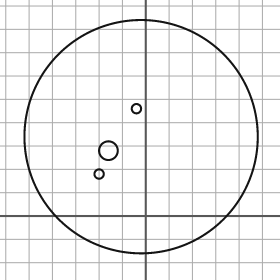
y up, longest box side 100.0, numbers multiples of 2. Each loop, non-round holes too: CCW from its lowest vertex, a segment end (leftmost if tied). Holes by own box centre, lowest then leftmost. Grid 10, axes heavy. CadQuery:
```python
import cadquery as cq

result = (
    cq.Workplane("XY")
    .moveTo(-2.0, 34.0)
    .circle(50.0)
    .moveTo(-20.0, 18.0)
    .circle(2.0)
    .moveTo(-16.0, 28.0)
    .circle(4.0)
    .moveTo(-4.0, 46.0)
    .circle(2.0)
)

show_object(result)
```